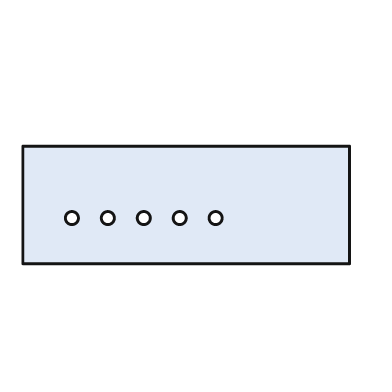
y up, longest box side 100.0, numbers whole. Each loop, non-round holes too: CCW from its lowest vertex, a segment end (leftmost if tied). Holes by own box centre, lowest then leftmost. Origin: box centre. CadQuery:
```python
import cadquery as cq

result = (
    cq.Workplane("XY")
    .moveTo(-50.0, -18.0)
    .lineTo(50.0, -18.0)
    .lineTo(50.0, 18.0)
    .lineTo(-50.0, 18.0)
    .close()
    .moveTo(-35.0, -4.0)
    .circle(2.0)
    .moveTo(-24.0, -4.0)
    .circle(2.0)
    .moveTo(-13.0, -4.0)
    .circle(2.0)
    .moveTo(-2.0, -4.0)
    .circle(2.0)
    .moveTo(9.0, -4.0)
    .circle(2.0)
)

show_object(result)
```